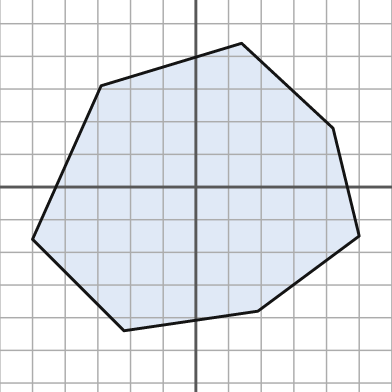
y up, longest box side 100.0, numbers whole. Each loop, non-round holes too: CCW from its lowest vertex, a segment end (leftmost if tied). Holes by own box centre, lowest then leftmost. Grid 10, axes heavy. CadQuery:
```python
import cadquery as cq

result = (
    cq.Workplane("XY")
    .moveTo(-22.0, -44.0)
    .lineTo(19.0, -38.0)
    .lineTo(50.0, -15.0)
    .lineTo(42.0, 18.0)
    .lineTo(14.0, 44.0)
    .lineTo(-29.0, 31.0)
    .lineTo(-50.0, -16.0)
    .close()
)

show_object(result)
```